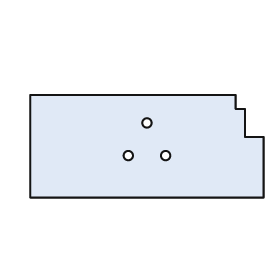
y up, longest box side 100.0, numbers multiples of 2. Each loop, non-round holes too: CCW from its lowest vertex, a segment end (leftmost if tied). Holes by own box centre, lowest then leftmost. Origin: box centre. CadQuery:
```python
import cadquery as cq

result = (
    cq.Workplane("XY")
    .moveTo(-50.0, -22.0)
    .lineTo(50.0, -22.0)
    .lineTo(50.0, 4.0)
    .lineTo(42.0, 4.0)
    .lineTo(42.0, 16.0)
    .lineTo(38.0, 16.0)
    .lineTo(38.0, 22.0)
    .lineTo(-50.0, 22.0)
    .close()
    .moveTo(-8.0, -4.0)
    .circle(2.0)
    .moveTo(8.0, -4.0)
    .circle(2.0)
    .moveTo(0.0, 10.0)
    .circle(2.0)
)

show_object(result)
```